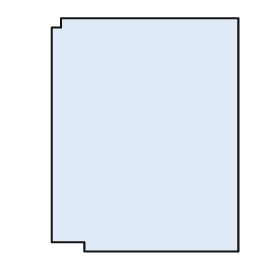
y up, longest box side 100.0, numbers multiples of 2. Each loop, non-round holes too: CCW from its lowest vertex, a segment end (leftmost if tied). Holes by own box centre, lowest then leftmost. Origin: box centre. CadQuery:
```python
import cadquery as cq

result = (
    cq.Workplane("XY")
    .moveTo(-26.0, -50.0)
    .lineTo(40.0, -50.0)
    .lineTo(40.0, 50.0)
    .lineTo(-36.0, 50.0)
    .lineTo(-36.0, 46.0)
    .lineTo(-40.0, 46.0)
    .lineTo(-40.0, -46.0)
    .lineTo(-26.0, -46.0)
    .close()
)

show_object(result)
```